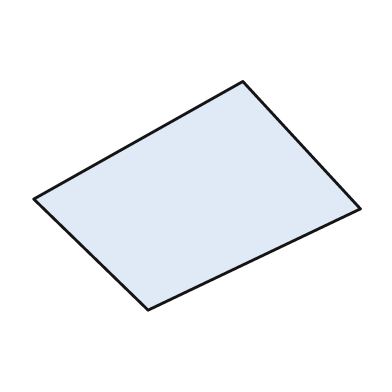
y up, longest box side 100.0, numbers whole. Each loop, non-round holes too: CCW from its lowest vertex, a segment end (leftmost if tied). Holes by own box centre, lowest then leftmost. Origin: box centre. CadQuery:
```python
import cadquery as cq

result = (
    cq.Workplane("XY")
    .moveTo(-15.0, -35.0)
    .lineTo(50.0, -4.0)
    .lineTo(14.0, 35.0)
    .lineTo(-50.0, -1.0)
    .close()
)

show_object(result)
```